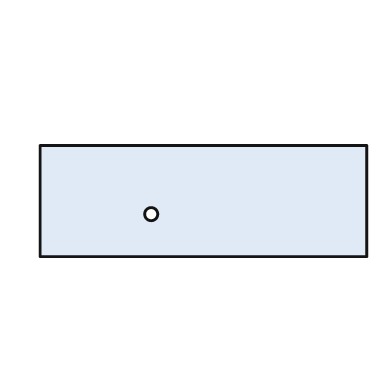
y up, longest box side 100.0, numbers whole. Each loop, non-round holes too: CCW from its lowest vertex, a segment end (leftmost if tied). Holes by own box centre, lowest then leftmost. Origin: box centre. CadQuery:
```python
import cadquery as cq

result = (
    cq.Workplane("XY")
    .moveTo(-50.0, -17.0)
    .lineTo(50.0, -17.0)
    .lineTo(50.0, 17.0)
    .lineTo(-50.0, 17.0)
    .close()
    .moveTo(-16.0, -4.0)
    .circle(2.0)
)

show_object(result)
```